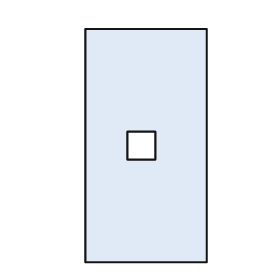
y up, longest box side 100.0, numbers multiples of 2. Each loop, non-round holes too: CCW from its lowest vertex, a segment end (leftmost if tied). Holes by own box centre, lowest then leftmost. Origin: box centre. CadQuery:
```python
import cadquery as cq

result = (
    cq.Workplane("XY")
    .moveTo(-26.0, -50.0)
    .lineTo(26.0, -50.0)
    .lineTo(26.0, 50.0)
    .lineTo(-26.0, 50.0)
    .close()
    .moveTo(-8.0, -6.0)
    .lineTo(4.0, -6.0)
    .lineTo(4.0, 6.0)
    .lineTo(-8.0, 6.0)
    .close()
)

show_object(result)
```